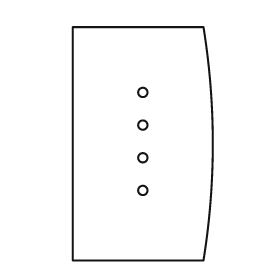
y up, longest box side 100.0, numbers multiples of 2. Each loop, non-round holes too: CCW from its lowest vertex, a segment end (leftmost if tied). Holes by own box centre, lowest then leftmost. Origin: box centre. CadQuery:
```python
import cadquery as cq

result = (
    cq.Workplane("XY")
    .moveTo(-30.0, -50.0)
    .lineTo(26.0, -50.0)
    .threePointArc((30.0, 0.0), (26.0, 50.0))
    .lineTo(-30.0, 50.0)
    .close()
    .moveTo(0.0, -20.0)
    .circle(2.0)
    .moveTo(0.0, -6.0)
    .circle(2.0)
    .moveTo(0.0, 8.0)
    .circle(2.0)
    .moveTo(0.0, 22.0)
    .circle(2.0)
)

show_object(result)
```